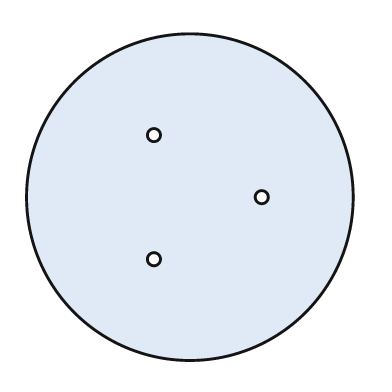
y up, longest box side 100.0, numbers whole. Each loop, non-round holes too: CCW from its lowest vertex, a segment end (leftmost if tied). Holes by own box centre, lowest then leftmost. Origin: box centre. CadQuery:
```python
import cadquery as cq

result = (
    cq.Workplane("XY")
    .moveTo(0.0, 0.0)
    .circle(50.0)
    .moveTo(-11.0, -19.0)
    .circle(2.0)
    .moveTo(22.0, 0.0)
    .circle(2.0)
    .moveTo(-11.0, 19.0)
    .circle(2.0)
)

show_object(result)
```